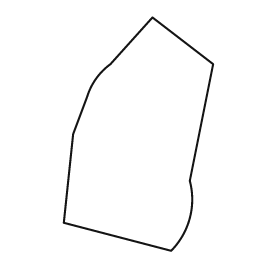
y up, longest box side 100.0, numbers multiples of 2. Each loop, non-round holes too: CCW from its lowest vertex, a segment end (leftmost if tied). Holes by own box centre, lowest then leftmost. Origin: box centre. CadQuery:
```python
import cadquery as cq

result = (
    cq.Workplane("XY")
    .moveTo(14.0, -50.0)
    .threePointArc((22.0, -36.0), (22.0, -20.0))
    .lineTo(32.0, 30.0)
    .lineTo(6.0, 50.0)
    .lineTo(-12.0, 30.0)
    .threePointArc((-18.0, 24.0), (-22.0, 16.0))
    .lineTo(-28.0, 0.0)
    .lineTo(-32.0, -38.0)
    .close()
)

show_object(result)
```